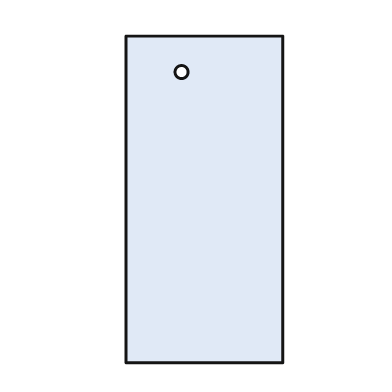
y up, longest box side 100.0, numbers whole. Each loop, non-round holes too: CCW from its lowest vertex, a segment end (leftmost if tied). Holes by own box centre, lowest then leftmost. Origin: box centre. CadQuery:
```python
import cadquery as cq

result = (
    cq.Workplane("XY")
    .moveTo(-24.0, -50.0)
    .lineTo(24.0, -50.0)
    .lineTo(24.0, 50.0)
    .lineTo(-24.0, 50.0)
    .close()
    .moveTo(-7.0, 39.0)
    .circle(2.0)
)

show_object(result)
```